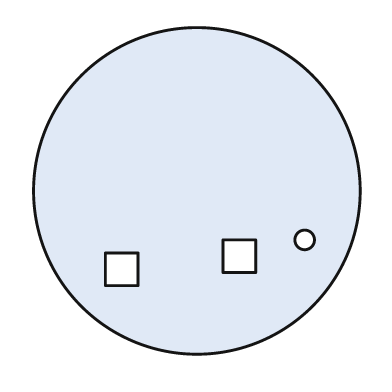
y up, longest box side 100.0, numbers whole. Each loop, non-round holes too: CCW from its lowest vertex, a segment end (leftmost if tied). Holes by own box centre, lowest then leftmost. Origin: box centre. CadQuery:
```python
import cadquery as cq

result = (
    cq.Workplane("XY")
    .moveTo(0.0, 0.0)
    .circle(50.0)
    .moveTo(-28.0, -29.0)
    .lineTo(-18.0, -29.0)
    .lineTo(-18.0, -19.0)
    .lineTo(-28.0, -19.0)
    .close()
    .moveTo(8.0, -25.0)
    .lineTo(18.0, -25.0)
    .lineTo(18.0, -15.0)
    .lineTo(8.0, -15.0)
    .close()
    .moveTo(33.0, -15.0)
    .circle(3.0)
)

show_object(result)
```